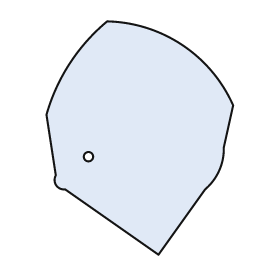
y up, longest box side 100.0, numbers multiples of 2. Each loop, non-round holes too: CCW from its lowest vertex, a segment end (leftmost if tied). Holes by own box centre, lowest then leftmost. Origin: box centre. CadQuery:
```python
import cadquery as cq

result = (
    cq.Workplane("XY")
    .moveTo(8.0, -50.0)
    .lineTo(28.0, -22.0)
    .threePointArc((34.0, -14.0), (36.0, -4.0))
    .lineTo(40.0, 14.0)
    .threePointArc((18.0, 40.0), (-14.0, 50.0))
    .threePointArc((-30.0, 32.0), (-40.0, 10.0))
    .lineTo(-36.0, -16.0)
    .threePointArc((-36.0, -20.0), (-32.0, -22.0))
    .close()
    .moveTo(-22.0, -8.0)
    .circle(2.0)
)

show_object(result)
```